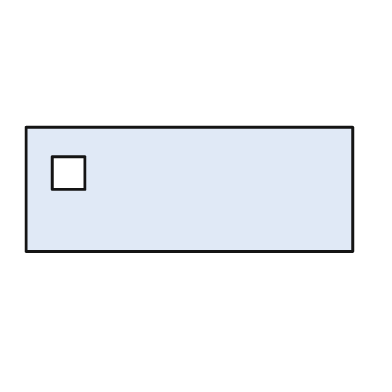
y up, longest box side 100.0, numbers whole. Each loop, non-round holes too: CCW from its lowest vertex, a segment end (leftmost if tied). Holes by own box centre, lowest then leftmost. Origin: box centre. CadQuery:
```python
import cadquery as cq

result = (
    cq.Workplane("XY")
    .moveTo(-50.0, -19.0)
    .lineTo(50.0, -19.0)
    .lineTo(50.0, 19.0)
    .lineTo(-50.0, 19.0)
    .close()
    .moveTo(-42.0, 0.0)
    .lineTo(-32.0, 0.0)
    .lineTo(-32.0, 10.0)
    .lineTo(-42.0, 10.0)
    .close()
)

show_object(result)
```